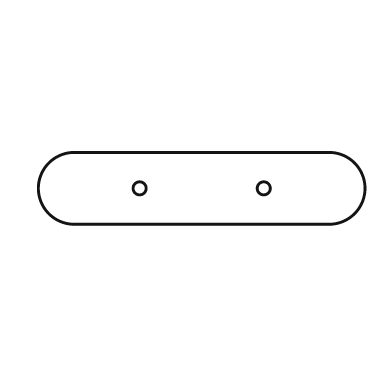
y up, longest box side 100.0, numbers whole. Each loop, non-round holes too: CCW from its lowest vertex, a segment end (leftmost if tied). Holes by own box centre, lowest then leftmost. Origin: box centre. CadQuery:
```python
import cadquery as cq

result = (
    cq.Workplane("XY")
    .moveTo(-39.0, -11.0)
    .lineTo(39.0, -11.0)
    .threePointArc((50.0, 0.0), (39.0, 11.0))
    .lineTo(-39.0, 11.0)
    .threePointArc((-50.0, 0.0), (-39.0, -11.0))
    .close()
    .moveTo(-19.0, 0.0)
    .circle(2.0)
    .moveTo(19.0, 0.0)
    .circle(2.0)
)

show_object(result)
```